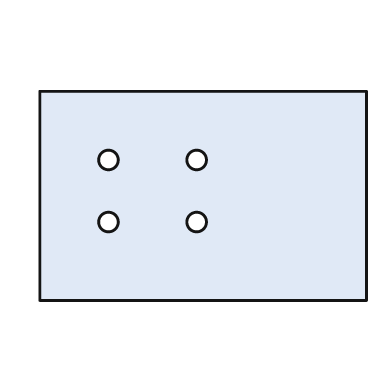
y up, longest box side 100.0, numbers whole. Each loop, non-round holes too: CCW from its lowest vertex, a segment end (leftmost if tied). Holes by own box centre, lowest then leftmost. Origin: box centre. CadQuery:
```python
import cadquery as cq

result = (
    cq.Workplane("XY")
    .moveTo(-50.0, -32.0)
    .lineTo(50.0, -32.0)
    .lineTo(50.0, 32.0)
    .lineTo(-50.0, 32.0)
    .close()
    .moveTo(-29.0, -8.0)
    .circle(3.0)
    .moveTo(-2.0, -8.0)
    .circle(3.0)
    .moveTo(-29.0, 11.0)
    .circle(3.0)
    .moveTo(-2.0, 11.0)
    .circle(3.0)
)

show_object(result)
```